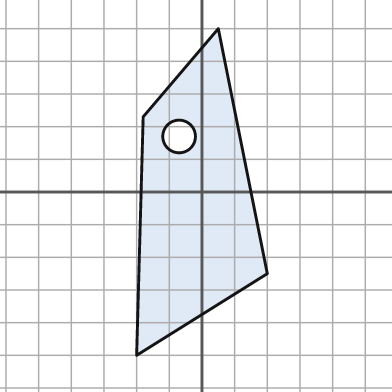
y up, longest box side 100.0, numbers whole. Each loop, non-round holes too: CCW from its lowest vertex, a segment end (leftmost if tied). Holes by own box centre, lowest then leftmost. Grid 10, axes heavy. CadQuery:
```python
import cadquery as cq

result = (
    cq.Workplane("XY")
    .moveTo(-20.0, -50.0)
    .lineTo(20.0, -25.0)
    .lineTo(5.0, 50.0)
    .lineTo(-18.0, 23.0)
    .close()
    .moveTo(-7.0, 17.0)
    .circle(5.0)
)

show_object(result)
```